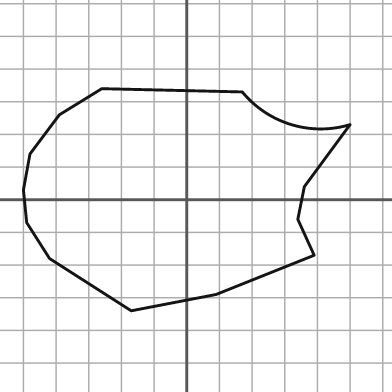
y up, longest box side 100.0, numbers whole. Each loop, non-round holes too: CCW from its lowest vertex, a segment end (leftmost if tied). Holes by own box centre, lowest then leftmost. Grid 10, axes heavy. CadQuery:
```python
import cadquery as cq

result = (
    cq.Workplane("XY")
    .moveTo(-17.0, -34.0)
    .lineTo(9.0, -29.0)
    .lineTo(39.0, -17.0)
    .lineTo(34.0, -6.0)
    .lineTo(36.0, 4.0)
    .lineTo(50.0, 23.0)
    .threePointArc((32.0, 23.0), (17.0, 33.0))
    .lineTo(-26.0, 34.0)
    .lineTo(-39.0, 26.0)
    .lineTo(-48.0, 14.0)
    .lineTo(-50.0, 3.0)
    .lineTo(-49.0, -7.0)
    .lineTo(-42.0, -18.0)
    .close()
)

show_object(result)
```